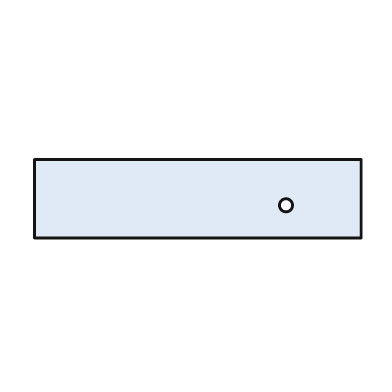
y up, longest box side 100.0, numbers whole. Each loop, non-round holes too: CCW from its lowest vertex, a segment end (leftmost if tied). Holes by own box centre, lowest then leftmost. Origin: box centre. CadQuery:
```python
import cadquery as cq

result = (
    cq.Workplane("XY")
    .moveTo(-50.0, -12.0)
    .lineTo(50.0, -12.0)
    .lineTo(50.0, 12.0)
    .lineTo(-50.0, 12.0)
    .close()
    .moveTo(27.0, -2.0)
    .circle(2.0)
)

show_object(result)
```